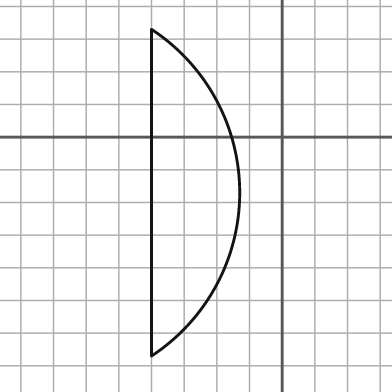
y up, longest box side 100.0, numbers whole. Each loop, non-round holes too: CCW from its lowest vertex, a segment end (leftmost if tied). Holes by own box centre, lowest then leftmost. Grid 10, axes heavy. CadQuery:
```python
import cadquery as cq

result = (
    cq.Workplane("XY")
    .moveTo(-40.0, -67.0)
    .threePointArc((-13.0, -17.0), (-40.0, 33.0))
    .close()
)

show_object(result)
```